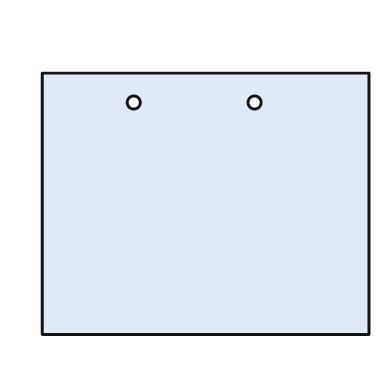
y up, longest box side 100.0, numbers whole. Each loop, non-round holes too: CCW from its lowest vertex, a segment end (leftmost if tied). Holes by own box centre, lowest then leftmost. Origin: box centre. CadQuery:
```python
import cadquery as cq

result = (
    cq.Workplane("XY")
    .moveTo(-50.0, -40.0)
    .lineTo(50.0, -40.0)
    .lineTo(50.0, 40.0)
    .lineTo(-50.0, 40.0)
    .close()
    .moveTo(-22.0, 31.0)
    .circle(2.0)
    .moveTo(15.0, 31.0)
    .circle(2.0)
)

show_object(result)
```